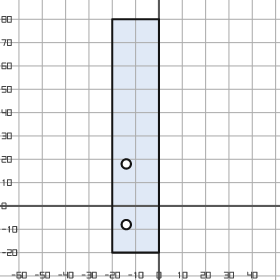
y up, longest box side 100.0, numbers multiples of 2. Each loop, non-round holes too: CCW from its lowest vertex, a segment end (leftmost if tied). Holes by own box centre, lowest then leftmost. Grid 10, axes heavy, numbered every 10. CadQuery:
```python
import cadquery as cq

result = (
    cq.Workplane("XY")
    .moveTo(-20.0, -20.0)
    .lineTo(0.0, -20.0)
    .lineTo(0.0, 80.0)
    .lineTo(-20.0, 80.0)
    .close()
    .moveTo(-14.0, -8.0)
    .circle(2.0)
    .moveTo(-14.0, 18.0)
    .circle(2.0)
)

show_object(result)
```